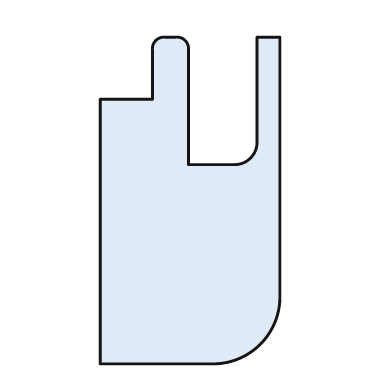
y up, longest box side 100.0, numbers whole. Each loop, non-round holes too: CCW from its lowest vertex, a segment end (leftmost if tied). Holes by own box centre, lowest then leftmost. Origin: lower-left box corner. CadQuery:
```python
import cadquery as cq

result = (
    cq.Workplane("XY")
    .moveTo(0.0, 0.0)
    .lineTo(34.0, 0.0)
    .threePointArc((49.0, 6.0), (55.0, 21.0))
    .lineTo(55.0, 100.0)
    .lineTo(48.0, 100.0)
    .lineTo(48.0, 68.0)
    .threePointArc((46.0, 63.0), (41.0, 61.0))
    .lineTo(27.0, 61.0)
    .lineTo(27.0, 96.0)
    .threePointArc((26.0, 99.0), (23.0, 100.0))
    .lineTo(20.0, 100.0)
    .threePointArc((17.0, 99.0), (16.0, 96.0))
    .lineTo(16.0, 81.0)
    .lineTo(0.0, 81.0)
    .close()
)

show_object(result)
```